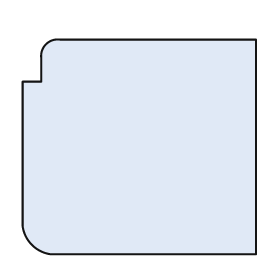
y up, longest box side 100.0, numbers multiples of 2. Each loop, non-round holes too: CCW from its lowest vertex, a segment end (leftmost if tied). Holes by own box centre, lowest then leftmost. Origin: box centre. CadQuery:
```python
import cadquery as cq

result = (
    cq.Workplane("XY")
    .moveTo(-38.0, -46.0)
    .lineTo(50.0, -46.0)
    .lineTo(50.0, 46.0)
    .lineTo(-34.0, 46.0)
    .threePointArc((-40.0, 44.0), (-42.0, 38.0))
    .lineTo(-42.0, 28.0)
    .lineTo(-50.0, 28.0)
    .lineTo(-50.0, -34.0)
    .threePointArc((-46.0, -42.0), (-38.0, -46.0))
    .close()
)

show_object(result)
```